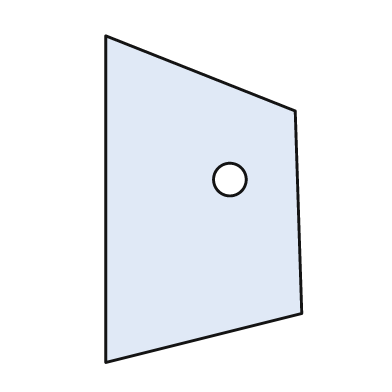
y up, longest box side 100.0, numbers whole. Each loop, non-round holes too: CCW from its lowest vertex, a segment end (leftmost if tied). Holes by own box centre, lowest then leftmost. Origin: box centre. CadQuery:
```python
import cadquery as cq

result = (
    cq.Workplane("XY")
    .moveTo(-30.0, -50.0)
    .lineTo(30.0, -35.0)
    .lineTo(28.0, 27.0)
    .lineTo(-30.0, 50.0)
    .close()
    .moveTo(8.0, 6.0)
    .circle(5.0)
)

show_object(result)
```